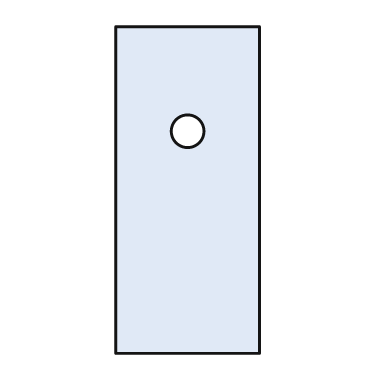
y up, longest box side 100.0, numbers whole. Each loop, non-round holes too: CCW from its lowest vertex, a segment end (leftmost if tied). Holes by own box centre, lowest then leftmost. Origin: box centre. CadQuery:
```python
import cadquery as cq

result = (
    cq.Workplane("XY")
    .moveTo(-22.0, -50.0)
    .lineTo(22.0, -50.0)
    .lineTo(22.0, 50.0)
    .lineTo(-22.0, 50.0)
    .close()
    .moveTo(0.0, 18.0)
    .circle(5.0)
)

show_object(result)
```